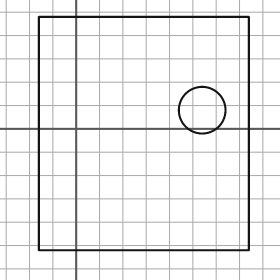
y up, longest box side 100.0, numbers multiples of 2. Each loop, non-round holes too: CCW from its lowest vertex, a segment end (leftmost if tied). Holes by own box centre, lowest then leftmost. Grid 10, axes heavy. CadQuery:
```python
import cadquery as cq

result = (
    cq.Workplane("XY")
    .moveTo(-16.0, -52.0)
    .lineTo(74.0, -52.0)
    .lineTo(74.0, 48.0)
    .lineTo(-16.0, 48.0)
    .close()
    .moveTo(54.0, 8.0)
    .circle(10.0)
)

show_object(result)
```